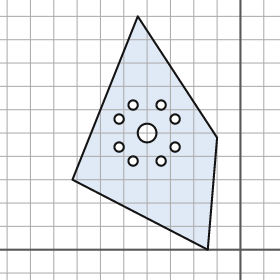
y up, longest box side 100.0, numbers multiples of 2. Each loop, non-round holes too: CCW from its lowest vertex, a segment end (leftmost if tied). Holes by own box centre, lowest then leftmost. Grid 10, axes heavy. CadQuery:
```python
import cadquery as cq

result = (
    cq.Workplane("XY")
    .moveTo(-14.0, 0.0)
    .lineTo(-10.0, 48.0)
    .lineTo(-44.0, 100.0)
    .lineTo(-72.0, 30.0)
    .close()
    .moveTo(-46.0, 38.0)
    .circle(2.0)
    .moveTo(-34.0, 38.0)
    .circle(2.0)
    .moveTo(-52.0, 44.0)
    .circle(2.0)
    .moveTo(-28.0, 44.0)
    .circle(2.0)
    .moveTo(-40.0, 50.0)
    .circle(4.0)
    .moveTo(-52.0, 56.0)
    .circle(2.0)
    .moveTo(-28.0, 56.0)
    .circle(2.0)
    .moveTo(-46.0, 62.0)
    .circle(2.0)
    .moveTo(-34.0, 62.0)
    .circle(2.0)
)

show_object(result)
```